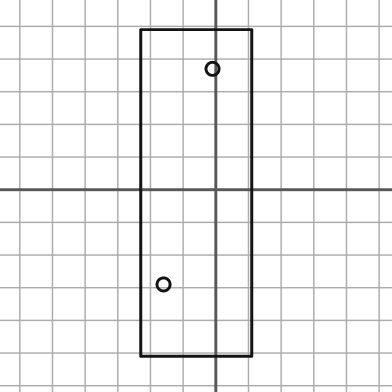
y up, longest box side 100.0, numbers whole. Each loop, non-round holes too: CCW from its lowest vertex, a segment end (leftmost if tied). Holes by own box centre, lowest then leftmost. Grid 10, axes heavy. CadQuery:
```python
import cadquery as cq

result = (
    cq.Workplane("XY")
    .moveTo(-23.0, -51.0)
    .lineTo(11.0, -51.0)
    .lineTo(11.0, 49.0)
    .lineTo(-23.0, 49.0)
    .close()
    .moveTo(-16.0, -29.0)
    .circle(2.0)
    .moveTo(-1.0, 37.0)
    .circle(2.0)
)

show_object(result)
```